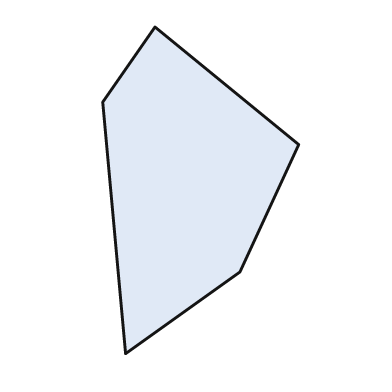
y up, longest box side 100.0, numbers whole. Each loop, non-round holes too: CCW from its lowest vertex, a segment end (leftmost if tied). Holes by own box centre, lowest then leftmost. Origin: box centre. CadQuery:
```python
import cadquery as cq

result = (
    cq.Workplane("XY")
    .moveTo(-23.0, -50.0)
    .lineTo(12.0, -25.0)
    .lineTo(30.0, 14.0)
    .lineTo(-14.0, 50.0)
    .lineTo(-30.0, 27.0)
    .close()
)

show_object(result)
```